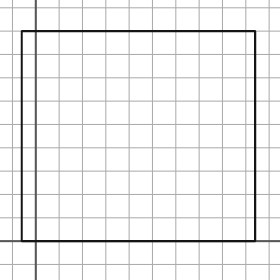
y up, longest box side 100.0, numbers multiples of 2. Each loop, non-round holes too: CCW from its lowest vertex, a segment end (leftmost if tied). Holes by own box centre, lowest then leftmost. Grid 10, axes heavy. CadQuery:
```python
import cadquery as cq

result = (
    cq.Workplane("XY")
    .moveTo(-6.0, 0.0)
    .lineTo(94.0, 0.0)
    .lineTo(94.0, 90.0)
    .lineTo(-6.0, 90.0)
    .close()
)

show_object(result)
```